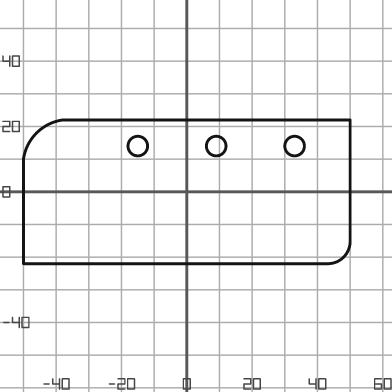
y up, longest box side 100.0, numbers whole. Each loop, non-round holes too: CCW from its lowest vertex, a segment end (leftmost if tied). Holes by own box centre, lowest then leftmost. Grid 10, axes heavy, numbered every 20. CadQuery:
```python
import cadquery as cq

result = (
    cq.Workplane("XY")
    .moveTo(-50.0, -22.0)
    .lineTo(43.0, -22.0)
    .threePointArc((48.0, -20.0), (50.0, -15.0))
    .lineTo(50.0, 22.0)
    .lineTo(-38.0, 22.0)
    .threePointArc((-46.0, 18.0), (-50.0, 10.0))
    .close()
    .moveTo(-15.0, 14.0)
    .circle(3.0)
    .moveTo(9.0, 14.0)
    .circle(3.0)
    .moveTo(33.0, 14.0)
    .circle(3.0)
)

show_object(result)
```